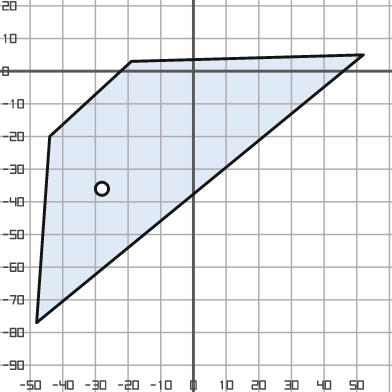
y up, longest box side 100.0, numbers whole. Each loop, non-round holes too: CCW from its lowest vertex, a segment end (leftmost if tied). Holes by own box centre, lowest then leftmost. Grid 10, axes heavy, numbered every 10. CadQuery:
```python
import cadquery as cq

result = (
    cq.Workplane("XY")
    .moveTo(-48.0, -77.0)
    .lineTo(52.0, 5.0)
    .lineTo(-19.0, 3.0)
    .lineTo(-44.0, -20.0)
    .close()
    .moveTo(-28.0, -36.0)
    .circle(2.0)
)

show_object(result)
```